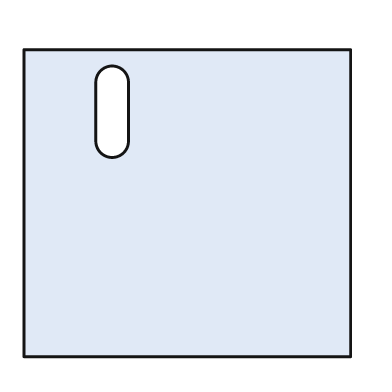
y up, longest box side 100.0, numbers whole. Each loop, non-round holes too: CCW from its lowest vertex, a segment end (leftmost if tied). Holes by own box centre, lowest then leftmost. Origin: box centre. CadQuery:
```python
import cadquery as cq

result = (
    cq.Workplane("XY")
    .moveTo(-50.0, -47.0)
    .lineTo(50.0, -47.0)
    .lineTo(50.0, 47.0)
    .lineTo(-50.0, 47.0)
    .close()
    .moveTo(-28.0, 19.0)
    .threePointArc((-23.0, 14.0), (-18.0, 19.0))
    .lineTo(-18.0, 37.0)
    .threePointArc((-23.0, 42.0), (-28.0, 37.0))
    .close()
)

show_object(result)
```